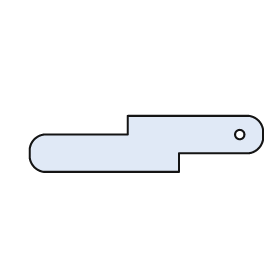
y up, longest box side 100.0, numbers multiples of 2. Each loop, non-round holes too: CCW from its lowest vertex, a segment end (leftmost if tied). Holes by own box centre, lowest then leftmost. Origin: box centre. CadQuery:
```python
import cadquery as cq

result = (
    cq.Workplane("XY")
    .moveTo(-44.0, -12.0)
    .lineTo(14.0, -12.0)
    .lineTo(14.0, -4.0)
    .lineTo(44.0, -4.0)
    .threePointArc((48.0, -2.0), (50.0, 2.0))
    .lineTo(50.0, 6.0)
    .threePointArc((48.0, 10.0), (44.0, 12.0))
    .lineTo(-8.0, 12.0)
    .lineTo(-8.0, 4.0)
    .lineTo(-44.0, 4.0)
    .threePointArc((-48.0, 2.0), (-50.0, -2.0))
    .lineTo(-50.0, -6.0)
    .threePointArc((-48.0, -10.0), (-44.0, -12.0))
    .close()
    .moveTo(40.0, 4.0)
    .circle(2.0)
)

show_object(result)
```